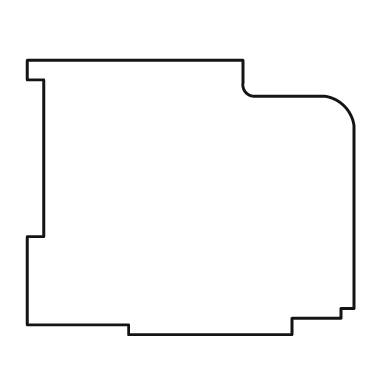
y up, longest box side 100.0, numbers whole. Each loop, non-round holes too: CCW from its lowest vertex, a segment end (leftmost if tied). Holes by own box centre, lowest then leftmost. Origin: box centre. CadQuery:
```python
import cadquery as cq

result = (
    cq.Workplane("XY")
    .moveTo(-19.0, -42.0)
    .lineTo(31.0, -42.0)
    .lineTo(31.0, -37.0)
    .lineTo(46.0, -37.0)
    .lineTo(46.0, -34.0)
    .lineTo(50.0, -34.0)
    .lineTo(50.0, 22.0)
    .threePointArc((47.0, 28.0), (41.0, 31.0))
    .lineTo(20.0, 31.0)
    .threePointArc((17.0, 32.0), (16.0, 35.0))
    .lineTo(16.0, 42.0)
    .lineTo(-50.0, 42.0)
    .lineTo(-50.0, 36.0)
    .lineTo(-45.0, 36.0)
    .lineTo(-45.0, -12.0)
    .lineTo(-50.0, -12.0)
    .lineTo(-50.0, -39.0)
    .lineTo(-19.0, -39.0)
    .close()
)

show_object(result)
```